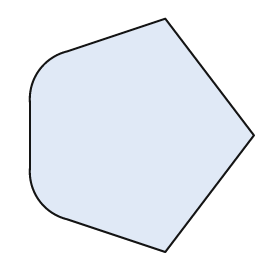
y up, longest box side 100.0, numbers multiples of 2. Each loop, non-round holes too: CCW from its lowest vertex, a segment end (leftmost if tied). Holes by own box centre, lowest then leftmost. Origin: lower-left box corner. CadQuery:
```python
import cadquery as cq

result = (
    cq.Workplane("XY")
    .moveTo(58.0, 0.0)
    .lineTo(96.0, 50.0)
    .lineTo(58.0, 100.0)
    .lineTo(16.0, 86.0)
    .threePointArc((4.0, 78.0), (0.0, 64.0))
    .lineTo(0.0, 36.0)
    .threePointArc((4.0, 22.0), (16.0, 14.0))
    .close()
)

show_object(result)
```